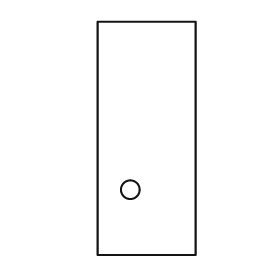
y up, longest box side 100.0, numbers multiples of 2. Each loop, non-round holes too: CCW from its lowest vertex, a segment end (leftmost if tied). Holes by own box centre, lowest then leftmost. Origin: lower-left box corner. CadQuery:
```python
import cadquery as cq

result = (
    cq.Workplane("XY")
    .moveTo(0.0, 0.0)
    .lineTo(42.0, 0.0)
    .lineTo(42.0, 100.0)
    .lineTo(0.0, 100.0)
    .close()
    .moveTo(14.0, 28.0)
    .circle(4.0)
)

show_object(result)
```